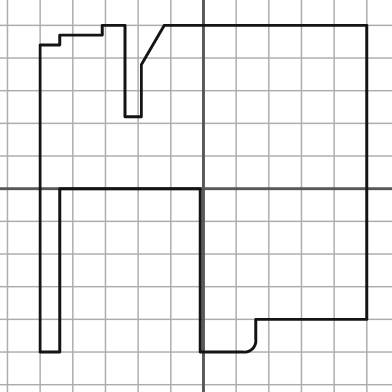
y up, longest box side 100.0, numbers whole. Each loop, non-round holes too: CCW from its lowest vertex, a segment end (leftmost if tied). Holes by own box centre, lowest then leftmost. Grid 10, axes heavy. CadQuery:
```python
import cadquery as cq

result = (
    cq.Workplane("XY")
    .moveTo(-50.0, -50.0)
    .lineTo(-44.0, -50.0)
    .lineTo(-44.0, 0.0)
    .lineTo(-1.0, 0.0)
    .lineTo(-1.0, -50.0)
    .lineTo(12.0, -50.0)
    .threePointArc((15.0, -49.0), (16.0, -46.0))
    .lineTo(16.0, -40.0)
    .lineTo(50.0, -40.0)
    .lineTo(50.0, 50.0)
    .lineTo(-12.0, 50.0)
    .lineTo(-19.0, 38.0)
    .lineTo(-19.0, 22.0)
    .lineTo(-24.0, 22.0)
    .lineTo(-24.0, 50.0)
    .lineTo(-31.0, 50.0)
    .lineTo(-31.0, 47.0)
    .lineTo(-44.0, 47.0)
    .lineTo(-44.0, 44.0)
    .lineTo(-50.0, 44.0)
    .close()
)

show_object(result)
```